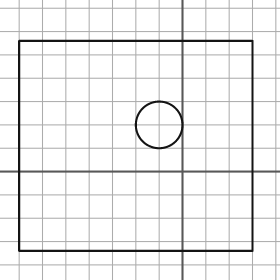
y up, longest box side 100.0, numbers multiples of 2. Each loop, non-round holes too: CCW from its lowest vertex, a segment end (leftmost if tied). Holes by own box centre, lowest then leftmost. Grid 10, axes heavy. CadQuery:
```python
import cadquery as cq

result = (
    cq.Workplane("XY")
    .moveTo(-70.0, -34.0)
    .lineTo(30.0, -34.0)
    .lineTo(30.0, 56.0)
    .lineTo(-70.0, 56.0)
    .close()
    .moveTo(-10.0, 20.0)
    .circle(10.0)
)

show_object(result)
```